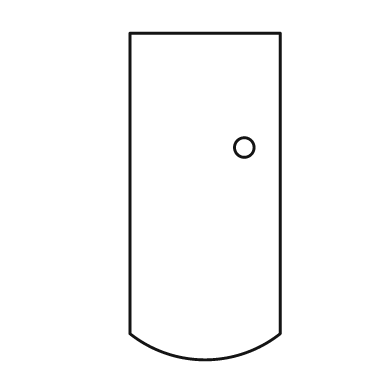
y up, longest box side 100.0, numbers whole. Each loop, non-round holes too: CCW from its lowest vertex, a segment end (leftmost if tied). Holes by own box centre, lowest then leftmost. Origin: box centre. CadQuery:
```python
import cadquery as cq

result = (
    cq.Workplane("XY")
    .moveTo(-23.0, -42.0)
    .threePointArc((0.0, -50.0), (23.0, -42.0))
    .lineTo(23.0, 50.0)
    .lineTo(-23.0, 50.0)
    .close()
    .moveTo(12.0, 15.0)
    .circle(3.0)
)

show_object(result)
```